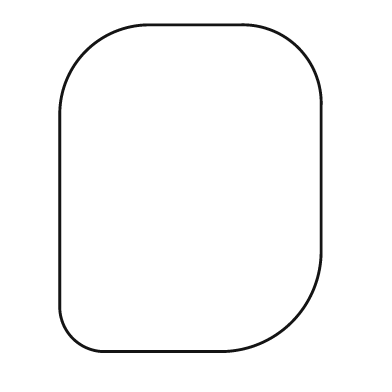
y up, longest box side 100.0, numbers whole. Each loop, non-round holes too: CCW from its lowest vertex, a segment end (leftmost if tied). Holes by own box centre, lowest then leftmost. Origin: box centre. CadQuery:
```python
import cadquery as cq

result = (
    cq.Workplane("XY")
    .moveTo(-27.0, -50.0)
    .lineTo(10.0, -50.0)
    .threePointArc((31.0, -41.0), (40.0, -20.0))
    .lineTo(40.0, 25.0)
    .threePointArc((33.0, 43.0), (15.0, 50.0))
    .lineTo(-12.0, 50.0)
    .threePointArc((-32.0, 42.0), (-40.0, 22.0))
    .lineTo(-40.0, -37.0)
    .threePointArc((-36.0, -46.0), (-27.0, -50.0))
    .close()
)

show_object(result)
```